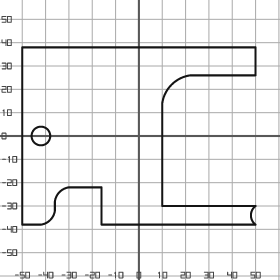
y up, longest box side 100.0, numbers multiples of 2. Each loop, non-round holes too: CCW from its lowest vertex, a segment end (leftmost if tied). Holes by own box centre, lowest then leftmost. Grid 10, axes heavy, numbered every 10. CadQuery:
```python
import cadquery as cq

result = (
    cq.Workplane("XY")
    .moveTo(-50.0, -38.0)
    .lineTo(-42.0, -38.0)
    .threePointArc((-38.0, -36.0), (-36.0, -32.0))
    .lineTo(-36.0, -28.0)
    .threePointArc((-34.0, -24.0), (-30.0, -22.0))
    .lineTo(-16.0, -22.0)
    .lineTo(-16.0, -38.0)
    .lineTo(50.0, -38.0)
    .threePointArc((48.0, -34.0), (50.0, -30.0))
    .lineTo(10.0, -30.0)
    .lineTo(10.0, 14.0)
    .threePointArc((14.0, 22.0), (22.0, 26.0))
    .lineTo(50.0, 26.0)
    .lineTo(50.0, 38.0)
    .lineTo(-50.0, 38.0)
    .close()
    .moveTo(-42.0, 0.0)
    .circle(4.0)
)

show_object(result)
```